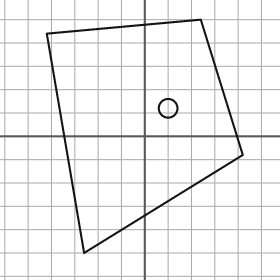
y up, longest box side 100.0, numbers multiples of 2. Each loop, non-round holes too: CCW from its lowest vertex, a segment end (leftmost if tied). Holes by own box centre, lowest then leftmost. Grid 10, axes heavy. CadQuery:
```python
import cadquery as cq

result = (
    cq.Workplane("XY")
    .moveTo(-26.0, -50.0)
    .lineTo(42.0, -8.0)
    .lineTo(24.0, 50.0)
    .lineTo(-42.0, 44.0)
    .close()
    .moveTo(10.0, 12.0)
    .circle(4.0)
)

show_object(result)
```